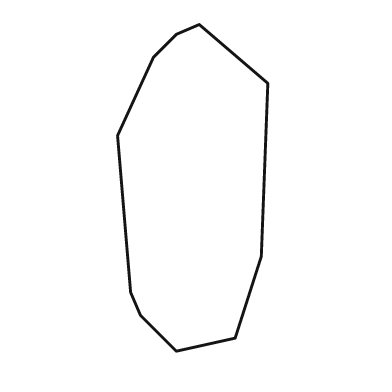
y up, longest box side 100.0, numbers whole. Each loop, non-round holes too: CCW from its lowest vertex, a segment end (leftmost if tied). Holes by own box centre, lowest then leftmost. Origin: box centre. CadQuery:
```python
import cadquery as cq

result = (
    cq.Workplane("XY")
    .moveTo(-5.0, -50.0)
    .lineTo(13.0, -46.0)
    .lineTo(21.0, -21.0)
    .lineTo(23.0, 32.0)
    .lineTo(2.0, 50.0)
    .lineTo(-5.0, 47.0)
    .lineTo(-12.0, 40.0)
    .lineTo(-23.0, 16.0)
    .lineTo(-19.0, -32.0)
    .lineTo(-16.0, -39.0)
    .close()
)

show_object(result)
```